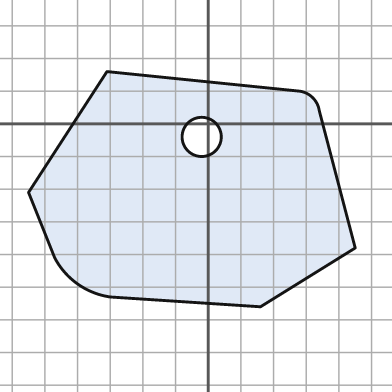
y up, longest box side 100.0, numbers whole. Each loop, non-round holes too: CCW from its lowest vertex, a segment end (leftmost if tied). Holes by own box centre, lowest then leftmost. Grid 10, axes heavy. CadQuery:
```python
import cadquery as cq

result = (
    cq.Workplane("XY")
    .moveTo(16.0, -56.0)
    .lineTo(45.0, -38.0)
    .lineTo(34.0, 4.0)
    .threePointArc((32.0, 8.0), (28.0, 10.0))
    .lineTo(-31.0, 16.0)
    .lineTo(-55.0, -21.0)
    .lineTo(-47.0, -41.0)
    .threePointArc((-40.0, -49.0), (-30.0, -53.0))
    .close()
    .moveTo(-2.0, -4.0)
    .circle(6.0)
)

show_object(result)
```